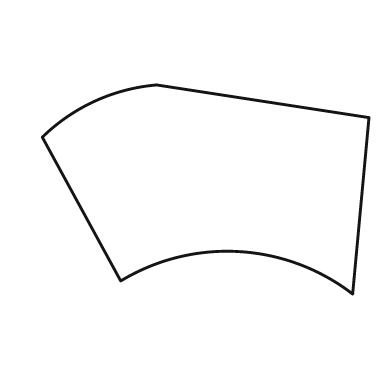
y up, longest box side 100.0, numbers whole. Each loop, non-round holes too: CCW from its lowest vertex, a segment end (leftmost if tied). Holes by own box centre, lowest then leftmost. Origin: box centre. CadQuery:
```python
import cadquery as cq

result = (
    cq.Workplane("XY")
    .moveTo(45.0, -32.0)
    .lineTo(50.0, 22.0)
    .lineTo(-15.0, 32.0)
    .threePointArc((-34.0, 27.0), (-50.0, 16.0))
    .lineTo(-26.0, -28.0)
    .threePointArc((10.0, -19.0), (45.0, -32.0))
    .close()
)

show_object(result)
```